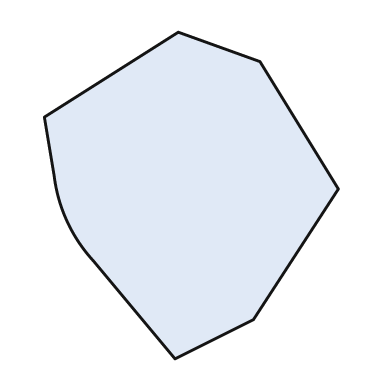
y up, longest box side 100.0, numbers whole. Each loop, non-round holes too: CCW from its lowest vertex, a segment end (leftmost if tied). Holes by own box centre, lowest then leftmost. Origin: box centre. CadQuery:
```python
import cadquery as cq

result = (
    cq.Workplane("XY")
    .moveTo(-5.0, -50.0)
    .lineTo(19.0, -38.0)
    .lineTo(45.0, 2.0)
    .lineTo(21.0, 41.0)
    .lineTo(-4.0, 50.0)
    .lineTo(-45.0, 24.0)
    .lineTo(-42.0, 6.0)
    .threePointArc((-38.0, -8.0), (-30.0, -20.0))
    .close()
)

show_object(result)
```